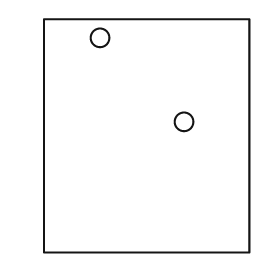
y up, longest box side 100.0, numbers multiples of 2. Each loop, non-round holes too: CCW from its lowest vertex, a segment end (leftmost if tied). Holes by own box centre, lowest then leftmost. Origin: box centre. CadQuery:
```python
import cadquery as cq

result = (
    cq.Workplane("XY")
    .moveTo(-44.0, -50.0)
    .lineTo(44.0, -50.0)
    .lineTo(44.0, 50.0)
    .lineTo(-44.0, 50.0)
    .close()
    .moveTo(16.0, 6.0)
    .circle(4.0)
    .moveTo(-20.0, 42.0)
    .circle(4.0)
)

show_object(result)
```